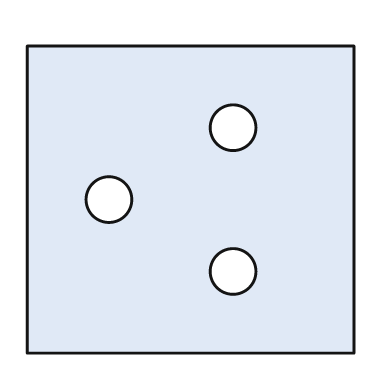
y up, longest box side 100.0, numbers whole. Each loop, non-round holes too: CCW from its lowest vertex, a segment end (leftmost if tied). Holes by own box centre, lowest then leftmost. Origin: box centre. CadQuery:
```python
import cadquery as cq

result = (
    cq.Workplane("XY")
    .moveTo(-50.0, -47.0)
    .lineTo(50.0, -47.0)
    .lineTo(50.0, 47.0)
    .lineTo(-50.0, 47.0)
    .close()
    .moveTo(13.0, -22.0)
    .circle(7.0)
    .moveTo(-25.0, 0.0)
    .circle(7.0)
    .moveTo(13.0, 22.0)
    .circle(7.0)
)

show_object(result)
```